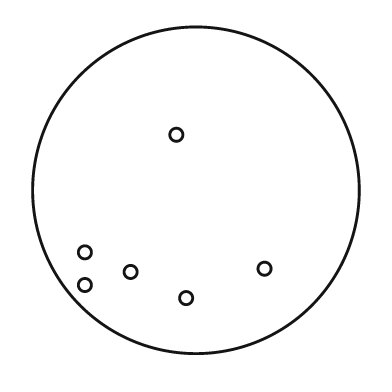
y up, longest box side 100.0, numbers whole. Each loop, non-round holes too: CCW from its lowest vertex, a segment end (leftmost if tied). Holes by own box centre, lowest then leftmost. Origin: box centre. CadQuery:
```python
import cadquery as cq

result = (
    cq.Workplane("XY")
    .moveTo(0.0, 0.0)
    .circle(50.0)
    .moveTo(-3.0, -33.0)
    .circle(2.0)
    .moveTo(-34.0, -29.0)
    .circle(2.0)
    .moveTo(-20.0, -25.0)
    .circle(2.0)
    .moveTo(21.0, -24.0)
    .circle(2.0)
    .moveTo(-34.0, -19.0)
    .circle(2.0)
    .moveTo(-6.0, 17.0)
    .circle(2.0)
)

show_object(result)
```